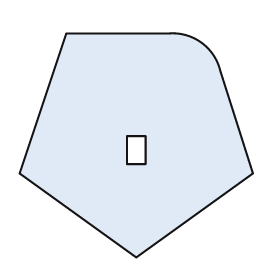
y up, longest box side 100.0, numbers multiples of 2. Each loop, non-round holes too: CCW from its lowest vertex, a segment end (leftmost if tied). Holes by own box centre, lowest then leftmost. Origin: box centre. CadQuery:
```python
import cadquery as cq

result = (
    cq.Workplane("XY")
    .moveTo(0.0, -48.0)
    .lineTo(50.0, -12.0)
    .lineTo(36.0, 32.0)
    .threePointArc((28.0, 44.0), (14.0, 48.0))
    .lineTo(-30.0, 48.0)
    .lineTo(-50.0, -12.0)
    .close()
    .moveTo(-4.0, -8.0)
    .lineTo(4.0, -8.0)
    .lineTo(4.0, 4.0)
    .lineTo(-4.0, 4.0)
    .close()
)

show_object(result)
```